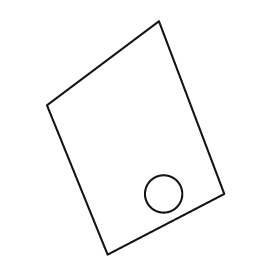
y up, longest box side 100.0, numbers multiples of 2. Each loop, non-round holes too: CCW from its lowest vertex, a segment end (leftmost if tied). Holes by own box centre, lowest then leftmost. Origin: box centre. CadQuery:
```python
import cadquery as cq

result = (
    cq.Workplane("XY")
    .moveTo(-12.0, -50.0)
    .lineTo(38.0, -24.0)
    .lineTo(10.0, 50.0)
    .lineTo(-38.0, 14.0)
    .close()
    .moveTo(12.0, -24.0)
    .circle(8.0)
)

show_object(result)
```